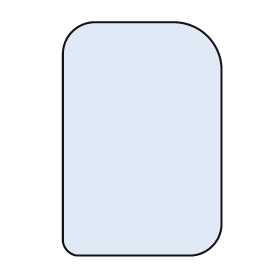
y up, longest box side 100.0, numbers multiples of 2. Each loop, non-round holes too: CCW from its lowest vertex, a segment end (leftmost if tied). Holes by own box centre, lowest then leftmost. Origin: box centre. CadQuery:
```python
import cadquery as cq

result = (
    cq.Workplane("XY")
    .moveTo(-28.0, -50.0)
    .lineTo(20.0, -50.0)
    .threePointArc((30.0, -46.0), (34.0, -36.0))
    .lineTo(34.0, 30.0)
    .threePointArc((28.0, 44.0), (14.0, 50.0))
    .lineTo(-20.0, 50.0)
    .threePointArc((-30.0, 46.0), (-34.0, 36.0))
    .lineTo(-34.0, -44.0)
    .threePointArc((-32.0, -48.0), (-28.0, -50.0))
    .close()
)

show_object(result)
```